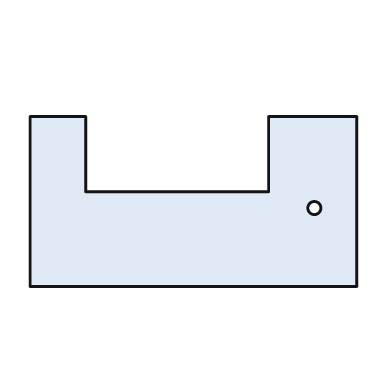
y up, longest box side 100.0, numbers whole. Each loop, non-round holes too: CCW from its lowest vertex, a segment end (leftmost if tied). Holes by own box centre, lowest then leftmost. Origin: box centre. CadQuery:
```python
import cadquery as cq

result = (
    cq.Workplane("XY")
    .moveTo(-50.0, -26.0)
    .lineTo(50.0, -26.0)
    .lineTo(50.0, 26.0)
    .lineTo(23.0, 26.0)
    .lineTo(23.0, 3.0)
    .lineTo(-33.0, 3.0)
    .lineTo(-33.0, 26.0)
    .lineTo(-50.0, 26.0)
    .close()
    .moveTo(37.0, -2.0)
    .circle(2.0)
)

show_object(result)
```